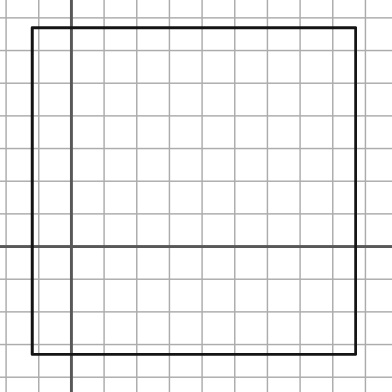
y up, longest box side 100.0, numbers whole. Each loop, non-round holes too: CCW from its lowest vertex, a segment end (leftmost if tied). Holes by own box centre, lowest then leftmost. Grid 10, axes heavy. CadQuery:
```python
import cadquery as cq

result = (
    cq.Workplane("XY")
    .moveTo(-12.0, -33.0)
    .lineTo(87.0, -33.0)
    .lineTo(87.0, 67.0)
    .lineTo(-12.0, 67.0)
    .close()
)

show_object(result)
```